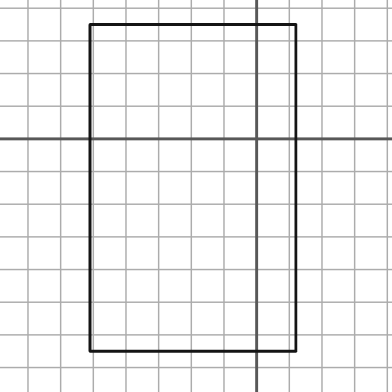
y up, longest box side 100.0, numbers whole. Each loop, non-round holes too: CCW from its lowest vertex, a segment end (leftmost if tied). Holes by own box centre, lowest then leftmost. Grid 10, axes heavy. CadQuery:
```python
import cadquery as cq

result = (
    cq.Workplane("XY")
    .moveTo(-51.0, -65.0)
    .lineTo(12.0, -65.0)
    .lineTo(12.0, 35.0)
    .lineTo(-51.0, 35.0)
    .close()
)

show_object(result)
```